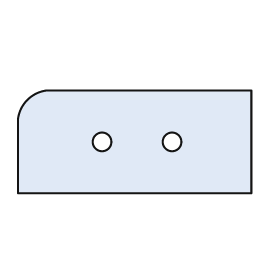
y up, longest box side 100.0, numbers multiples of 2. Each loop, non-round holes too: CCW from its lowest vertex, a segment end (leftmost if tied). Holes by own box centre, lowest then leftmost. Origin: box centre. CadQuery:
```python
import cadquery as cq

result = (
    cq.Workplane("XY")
    .moveTo(-50.0, -22.0)
    .lineTo(50.0, -22.0)
    .lineTo(50.0, 22.0)
    .lineTo(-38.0, 22.0)
    .threePointArc((-46.0, 18.0), (-50.0, 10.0))
    .close()
    .moveTo(-14.0, 0.0)
    .circle(4.0)
    .moveTo(16.0, 0.0)
    .circle(4.0)
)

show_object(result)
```